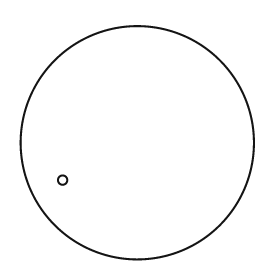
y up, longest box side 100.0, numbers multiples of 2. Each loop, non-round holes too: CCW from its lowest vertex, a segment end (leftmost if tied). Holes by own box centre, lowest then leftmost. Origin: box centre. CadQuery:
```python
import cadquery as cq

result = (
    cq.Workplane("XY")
    .moveTo(0.0, 0.0)
    .circle(50.0)
    .moveTo(-32.0, -16.0)
    .circle(2.0)
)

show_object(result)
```